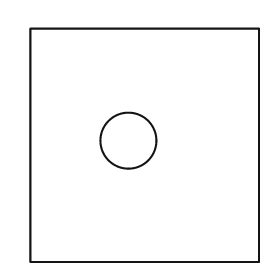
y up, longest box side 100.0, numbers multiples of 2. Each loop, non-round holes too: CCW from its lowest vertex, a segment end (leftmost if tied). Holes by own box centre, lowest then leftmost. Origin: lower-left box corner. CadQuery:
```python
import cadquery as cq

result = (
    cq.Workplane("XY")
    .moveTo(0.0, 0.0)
    .lineTo(98.0, 0.0)
    .lineTo(98.0, 100.0)
    .lineTo(0.0, 100.0)
    .close()
    .moveTo(42.0, 52.0)
    .circle(12.0)
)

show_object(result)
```